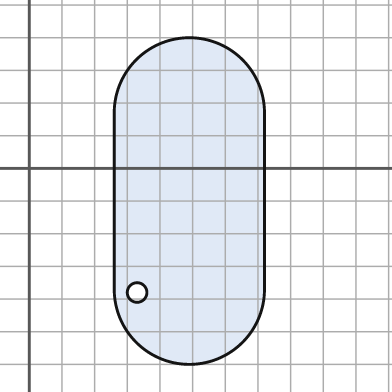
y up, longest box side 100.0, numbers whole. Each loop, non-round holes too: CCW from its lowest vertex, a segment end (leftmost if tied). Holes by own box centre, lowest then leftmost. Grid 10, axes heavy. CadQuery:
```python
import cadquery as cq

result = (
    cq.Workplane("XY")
    .moveTo(26.0, -37.0)
    .threePointArc((49.0, -60.0), (72.0, -37.0))
    .lineTo(72.0, 17.0)
    .threePointArc((49.0, 40.0), (26.0, 17.0))
    .close()
    .moveTo(33.0, -38.0)
    .circle(3.0)
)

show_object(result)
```